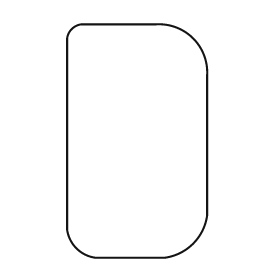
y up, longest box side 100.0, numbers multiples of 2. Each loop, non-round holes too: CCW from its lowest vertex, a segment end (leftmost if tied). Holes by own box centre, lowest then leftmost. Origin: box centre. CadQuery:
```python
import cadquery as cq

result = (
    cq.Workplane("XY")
    .moveTo(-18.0, -50.0)
    .lineTo(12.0, -50.0)
    .threePointArc((24.0, -44.0), (30.0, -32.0))
    .lineTo(30.0, 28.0)
    .threePointArc((24.0, 44.0), (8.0, 50.0))
    .lineTo(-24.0, 50.0)
    .threePointArc((-28.0, 48.0), (-30.0, 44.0))
    .lineTo(-30.0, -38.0)
    .threePointArc((-26.0, -46.0), (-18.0, -50.0))
    .close()
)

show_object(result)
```